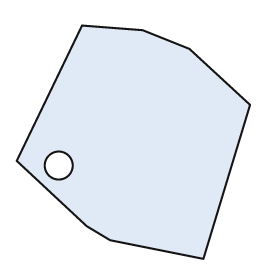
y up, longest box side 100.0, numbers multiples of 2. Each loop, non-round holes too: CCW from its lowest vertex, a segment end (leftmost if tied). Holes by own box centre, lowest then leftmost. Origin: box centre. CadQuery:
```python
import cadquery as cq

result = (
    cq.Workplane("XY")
    .moveTo(30.0, -50.0)
    .lineTo(50.0, 16.0)
    .lineTo(24.0, 40.0)
    .lineTo(4.0, 48.0)
    .lineTo(-22.0, 50.0)
    .lineTo(-50.0, -8.0)
    .lineTo(-20.0, -36.0)
    .lineTo(-10.0, -42.0)
    .close()
    .moveTo(-32.0, -10.0)
    .circle(6.0)
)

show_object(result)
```